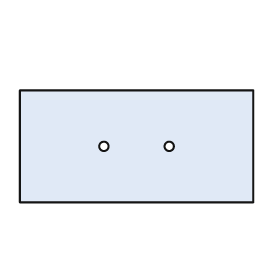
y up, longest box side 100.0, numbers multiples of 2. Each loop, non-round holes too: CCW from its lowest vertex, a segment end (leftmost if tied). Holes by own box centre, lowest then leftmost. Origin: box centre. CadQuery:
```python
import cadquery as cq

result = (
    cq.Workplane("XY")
    .moveTo(-50.0, -24.0)
    .lineTo(50.0, -24.0)
    .lineTo(50.0, 24.0)
    .lineTo(-50.0, 24.0)
    .close()
    .moveTo(-14.0, 0.0)
    .circle(2.0)
    .moveTo(14.0, 0.0)
    .circle(2.0)
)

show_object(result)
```